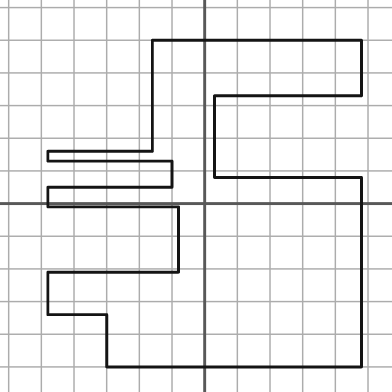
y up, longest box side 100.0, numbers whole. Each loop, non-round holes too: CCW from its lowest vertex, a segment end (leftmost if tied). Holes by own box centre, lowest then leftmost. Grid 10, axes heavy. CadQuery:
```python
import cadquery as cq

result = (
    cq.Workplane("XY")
    .moveTo(-30.0, -50.0)
    .lineTo(48.0, -50.0)
    .lineTo(48.0, 8.0)
    .lineTo(3.0, 8.0)
    .lineTo(3.0, 33.0)
    .lineTo(48.0, 33.0)
    .lineTo(48.0, 50.0)
    .lineTo(-16.0, 50.0)
    .lineTo(-16.0, 16.0)
    .lineTo(-48.0, 16.0)
    .lineTo(-48.0, 13.0)
    .lineTo(-10.0, 13.0)
    .lineTo(-10.0, 5.0)
    .lineTo(-48.0, 5.0)
    .lineTo(-48.0, -1.0)
    .lineTo(-8.0, -1.0)
    .lineTo(-8.0, -21.0)
    .lineTo(-48.0, -21.0)
    .lineTo(-48.0, -34.0)
    .lineTo(-30.0, -34.0)
    .close()
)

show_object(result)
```